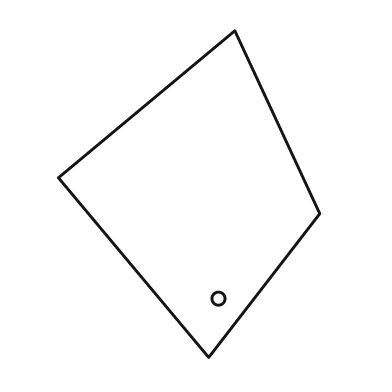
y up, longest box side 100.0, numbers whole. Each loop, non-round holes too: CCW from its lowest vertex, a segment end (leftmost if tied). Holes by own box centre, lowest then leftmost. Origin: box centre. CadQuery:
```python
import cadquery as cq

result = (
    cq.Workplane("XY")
    .moveTo(6.0, -50.0)
    .lineTo(40.0, -6.0)
    .lineTo(14.0, 50.0)
    .lineTo(-40.0, 5.0)
    .close()
    .moveTo(9.0, -32.0)
    .circle(2.0)
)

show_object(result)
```